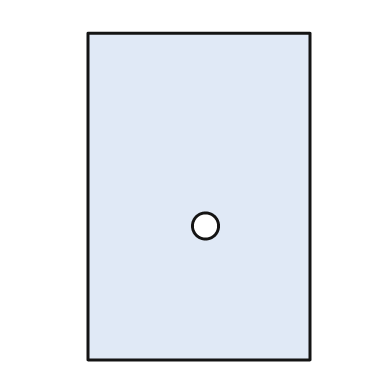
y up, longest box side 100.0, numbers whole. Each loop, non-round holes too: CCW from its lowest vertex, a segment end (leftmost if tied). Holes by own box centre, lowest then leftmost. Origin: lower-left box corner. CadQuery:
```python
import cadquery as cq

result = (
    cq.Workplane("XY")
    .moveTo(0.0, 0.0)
    .lineTo(68.0, 0.0)
    .lineTo(68.0, 100.0)
    .lineTo(0.0, 100.0)
    .close()
    .moveTo(36.0, 41.0)
    .circle(4.0)
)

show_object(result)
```